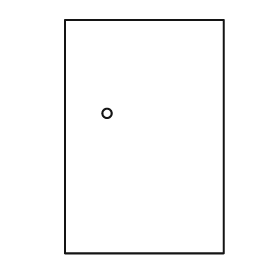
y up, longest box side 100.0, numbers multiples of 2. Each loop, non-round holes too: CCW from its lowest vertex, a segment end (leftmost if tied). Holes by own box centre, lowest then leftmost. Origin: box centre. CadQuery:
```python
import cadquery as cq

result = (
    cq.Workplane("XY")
    .moveTo(-34.0, -50.0)
    .lineTo(34.0, -50.0)
    .lineTo(34.0, 50.0)
    .lineTo(-34.0, 50.0)
    .close()
    .moveTo(-16.0, 10.0)
    .circle(2.0)
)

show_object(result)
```